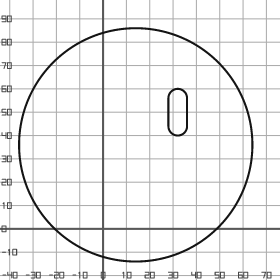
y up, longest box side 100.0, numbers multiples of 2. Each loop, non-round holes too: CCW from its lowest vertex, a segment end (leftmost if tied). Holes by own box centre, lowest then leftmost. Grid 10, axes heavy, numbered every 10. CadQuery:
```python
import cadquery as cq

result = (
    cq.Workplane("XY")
    .moveTo(14.0, 36.0)
    .circle(50.0)
    .moveTo(28.0, 44.0)
    .threePointArc((32.0, 40.0), (36.0, 44.0))
    .lineTo(36.0, 56.0)
    .threePointArc((32.0, 60.0), (28.0, 56.0))
    .close()
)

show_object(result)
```